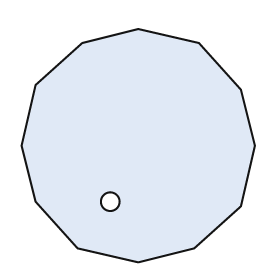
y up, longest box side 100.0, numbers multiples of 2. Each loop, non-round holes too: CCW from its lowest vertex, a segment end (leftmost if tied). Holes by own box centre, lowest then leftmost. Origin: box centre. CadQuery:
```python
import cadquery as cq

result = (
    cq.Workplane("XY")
    .moveTo(0.0, -50.0)
    .lineTo(24.0, -44.0)
    .lineTo(44.0, -26.0)
    .lineTo(50.0, 0.0)
    .lineTo(44.0, 24.0)
    .lineTo(26.0, 44.0)
    .lineTo(0.0, 50.0)
    .lineTo(-24.0, 44.0)
    .lineTo(-44.0, 26.0)
    .lineTo(-50.0, 0.0)
    .lineTo(-44.0, -24.0)
    .lineTo(-26.0, -44.0)
    .close()
    .moveTo(-12.0, -24.0)
    .circle(4.0)
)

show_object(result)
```